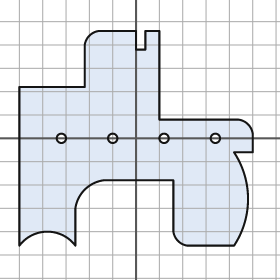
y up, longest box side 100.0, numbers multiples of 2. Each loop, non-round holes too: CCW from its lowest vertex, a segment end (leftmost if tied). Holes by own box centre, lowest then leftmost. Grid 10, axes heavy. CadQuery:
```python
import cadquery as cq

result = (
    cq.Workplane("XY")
    .moveTo(-50.0, -46.0)
    .threePointArc((-38.0, -40.0), (-26.0, -46.0))
    .lineTo(-26.0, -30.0)
    .threePointArc((-22.0, -22.0), (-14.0, -18.0))
    .lineTo(16.0, -18.0)
    .lineTo(16.0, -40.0)
    .threePointArc((18.0, -44.0), (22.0, -46.0))
    .lineTo(42.0, -46.0)
    .threePointArc((48.0, -26.0), (42.0, -6.0))
    .lineTo(50.0, -6.0)
    .lineTo(50.0, 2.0)
    .threePointArc((48.0, 6.0), (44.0, 8.0))
    .lineTo(10.0, 8.0)
    .lineTo(10.0, 46.0)
    .lineTo(4.0, 46.0)
    .lineTo(4.0, 38.0)
    .lineTo(0.0, 38.0)
    .lineTo(0.0, 46.0)
    .lineTo(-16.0, 46.0)
    .threePointArc((-20.0, 44.0), (-22.0, 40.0))
    .lineTo(-22.0, 22.0)
    .lineTo(-50.0, 22.0)
    .close()
    .moveTo(-32.0, 0.0)
    .circle(2.0)
    .moveTo(-10.0, 0.0)
    .circle(2.0)
    .moveTo(12.0, 0.0)
    .circle(2.0)
    .moveTo(34.0, 0.0)
    .circle(2.0)
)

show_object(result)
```